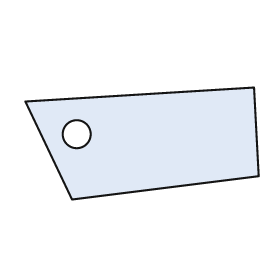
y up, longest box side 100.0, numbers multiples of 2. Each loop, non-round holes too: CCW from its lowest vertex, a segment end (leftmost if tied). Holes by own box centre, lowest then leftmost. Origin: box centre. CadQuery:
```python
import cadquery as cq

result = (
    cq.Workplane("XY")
    .moveTo(-30.0, -24.0)
    .lineTo(50.0, -14.0)
    .lineTo(48.0, 24.0)
    .lineTo(-50.0, 18.0)
    .close()
    .moveTo(-28.0, 4.0)
    .circle(6.0)
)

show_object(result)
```